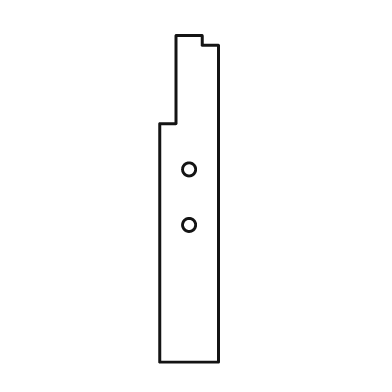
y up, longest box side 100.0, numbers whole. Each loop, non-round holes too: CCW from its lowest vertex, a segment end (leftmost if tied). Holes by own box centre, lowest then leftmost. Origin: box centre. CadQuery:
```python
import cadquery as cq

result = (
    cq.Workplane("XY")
    .moveTo(-9.0, -50.0)
    .lineTo(9.0, -50.0)
    .lineTo(9.0, 47.0)
    .lineTo(4.0, 47.0)
    .lineTo(4.0, 50.0)
    .lineTo(-4.0, 50.0)
    .lineTo(-4.0, 23.0)
    .lineTo(-9.0, 23.0)
    .close()
    .moveTo(0.0, -8.0)
    .circle(2.0)
    .moveTo(0.0, 9.0)
    .circle(2.0)
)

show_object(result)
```